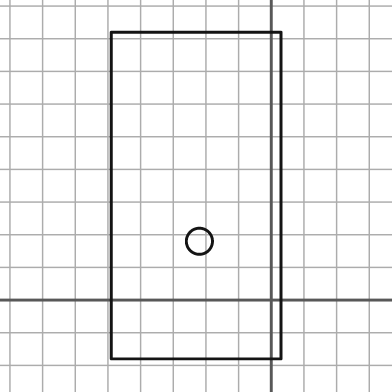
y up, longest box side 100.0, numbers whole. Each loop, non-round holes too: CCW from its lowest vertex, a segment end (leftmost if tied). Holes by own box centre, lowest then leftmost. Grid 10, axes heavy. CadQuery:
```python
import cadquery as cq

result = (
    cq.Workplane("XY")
    .moveTo(-49.0, -18.0)
    .lineTo(3.0, -18.0)
    .lineTo(3.0, 82.0)
    .lineTo(-49.0, 82.0)
    .close()
    .moveTo(-22.0, 18.0)
    .circle(4.0)
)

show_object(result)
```